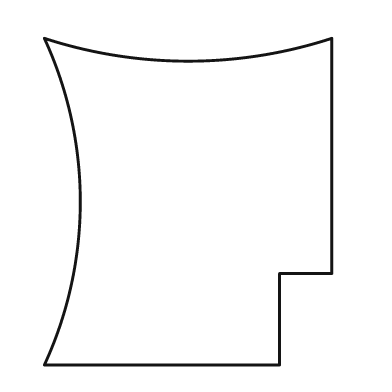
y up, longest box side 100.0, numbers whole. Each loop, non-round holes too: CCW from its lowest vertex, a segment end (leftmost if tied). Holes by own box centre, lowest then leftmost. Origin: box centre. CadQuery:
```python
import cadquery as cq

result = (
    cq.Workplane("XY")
    .moveTo(-44.0, -50.0)
    .lineTo(28.0, -50.0)
    .lineTo(28.0, -22.0)
    .lineTo(44.0, -22.0)
    .lineTo(44.0, 50.0)
    .threePointArc((0.0, 43.0), (-44.0, 50.0))
    .threePointArc((-33.0, 0.0), (-44.0, -50.0))
    .close()
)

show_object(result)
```